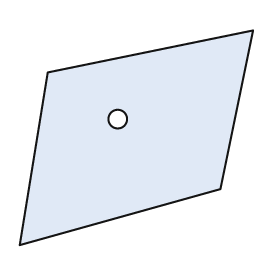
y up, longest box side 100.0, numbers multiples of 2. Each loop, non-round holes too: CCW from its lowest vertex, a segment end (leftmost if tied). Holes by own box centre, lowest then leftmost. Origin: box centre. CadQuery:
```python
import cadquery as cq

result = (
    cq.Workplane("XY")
    .moveTo(-50.0, -46.0)
    .lineTo(36.0, -22.0)
    .lineTo(50.0, 46.0)
    .lineTo(-38.0, 28.0)
    .close()
    .moveTo(-8.0, 8.0)
    .circle(4.0)
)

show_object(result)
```